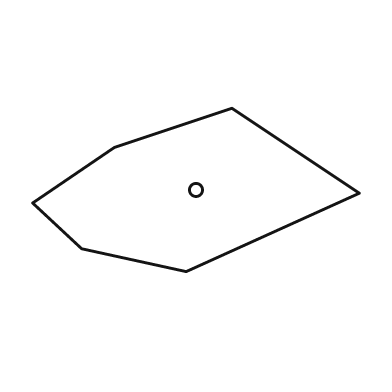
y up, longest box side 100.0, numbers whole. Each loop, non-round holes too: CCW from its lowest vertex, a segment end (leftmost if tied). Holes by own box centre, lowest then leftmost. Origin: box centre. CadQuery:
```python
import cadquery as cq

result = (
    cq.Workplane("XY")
    .moveTo(-3.0, -25.0)
    .lineTo(50.0, -1.0)
    .lineTo(11.0, 25.0)
    .lineTo(-25.0, 13.0)
    .lineTo(-50.0, -4.0)
    .lineTo(-35.0, -18.0)
    .close()
    .moveTo(0.0, 0.0)
    .circle(2.0)
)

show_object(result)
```